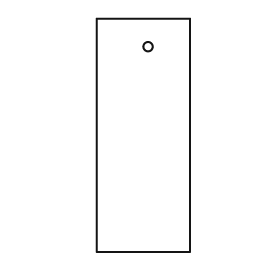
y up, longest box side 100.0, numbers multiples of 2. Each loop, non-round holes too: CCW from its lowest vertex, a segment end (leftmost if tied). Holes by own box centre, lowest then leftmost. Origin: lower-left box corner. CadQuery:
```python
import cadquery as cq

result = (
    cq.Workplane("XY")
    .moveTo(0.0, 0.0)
    .lineTo(40.0, 0.0)
    .lineTo(40.0, 100.0)
    .lineTo(0.0, 100.0)
    .close()
    .moveTo(22.0, 88.0)
    .circle(2.0)
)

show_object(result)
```